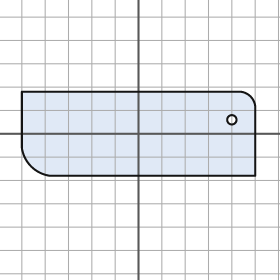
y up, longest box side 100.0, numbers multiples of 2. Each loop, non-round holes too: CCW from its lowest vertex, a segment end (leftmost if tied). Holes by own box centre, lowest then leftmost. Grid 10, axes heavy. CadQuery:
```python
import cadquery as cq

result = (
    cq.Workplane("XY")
    .moveTo(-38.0, -18.0)
    .lineTo(50.0, -18.0)
    .lineTo(50.0, 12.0)
    .threePointArc((48.0, 16.0), (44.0, 18.0))
    .lineTo(-50.0, 18.0)
    .lineTo(-50.0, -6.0)
    .threePointArc((-46.0, -14.0), (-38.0, -18.0))
    .close()
    .moveTo(40.0, 6.0)
    .circle(2.0)
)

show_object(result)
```